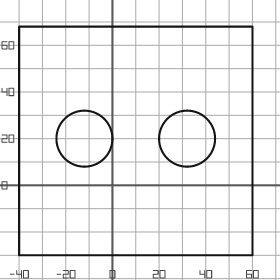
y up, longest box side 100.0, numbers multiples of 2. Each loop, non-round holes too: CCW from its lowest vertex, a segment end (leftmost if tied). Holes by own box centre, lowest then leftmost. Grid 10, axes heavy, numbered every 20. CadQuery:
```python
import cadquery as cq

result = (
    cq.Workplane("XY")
    .moveTo(-40.0, -30.0)
    .lineTo(60.0, -30.0)
    .lineTo(60.0, 68.0)
    .lineTo(-40.0, 68.0)
    .close()
    .moveTo(-12.0, 20.0)
    .circle(12.0)
    .moveTo(32.0, 20.0)
    .circle(12.0)
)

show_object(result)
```